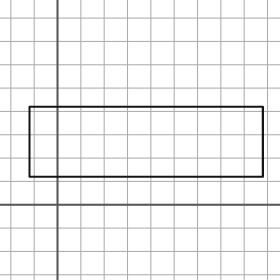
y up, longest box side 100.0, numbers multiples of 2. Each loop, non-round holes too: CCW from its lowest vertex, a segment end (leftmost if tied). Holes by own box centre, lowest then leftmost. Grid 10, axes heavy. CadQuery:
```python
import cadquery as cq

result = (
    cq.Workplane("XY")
    .moveTo(-12.0, 12.0)
    .lineTo(88.0, 12.0)
    .lineTo(88.0, 42.0)
    .lineTo(-12.0, 42.0)
    .close()
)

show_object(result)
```